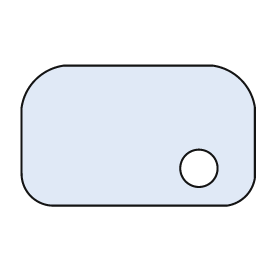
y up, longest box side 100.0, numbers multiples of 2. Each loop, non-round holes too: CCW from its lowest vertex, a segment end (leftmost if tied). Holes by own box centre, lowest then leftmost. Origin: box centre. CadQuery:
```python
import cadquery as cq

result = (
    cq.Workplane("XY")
    .moveTo(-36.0, -30.0)
    .lineTo(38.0, -30.0)
    .threePointArc((46.0, -26.0), (50.0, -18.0))
    .lineTo(50.0, 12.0)
    .threePointArc((44.0, 24.0), (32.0, 30.0))
    .lineTo(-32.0, 30.0)
    .threePointArc((-44.0, 24.0), (-50.0, 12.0))
    .lineTo(-50.0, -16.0)
    .threePointArc((-46.0, -26.0), (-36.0, -30.0))
    .close()
    .moveTo(26.0, -14.0)
    .circle(8.0)
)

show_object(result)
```